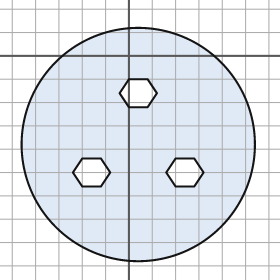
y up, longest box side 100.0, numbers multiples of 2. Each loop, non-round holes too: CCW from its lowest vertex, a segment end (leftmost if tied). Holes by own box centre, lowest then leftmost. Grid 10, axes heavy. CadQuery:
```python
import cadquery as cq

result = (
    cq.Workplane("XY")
    .moveTo(4.0, -38.0)
    .circle(50.0)
    .moveTo(-20.0, -56.0)
    .lineTo(-12.0, -56.0)
    .lineTo(-8.0, -50.0)
    .lineTo(-12.0, -44.0)
    .lineTo(-20.0, -44.0)
    .lineTo(-24.0, -50.0)
    .close()
    .moveTo(20.0, -56.0)
    .lineTo(28.0, -56.0)
    .lineTo(32.0, -50.0)
    .lineTo(28.0, -44.0)
    .lineTo(20.0, -44.0)
    .lineTo(16.0, -50.0)
    .close()
    .moveTo(0.0, -22.0)
    .lineTo(8.0, -22.0)
    .lineTo(12.0, -16.0)
    .lineTo(8.0, -10.0)
    .lineTo(0.0, -10.0)
    .lineTo(-4.0, -16.0)
    .close()
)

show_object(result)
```